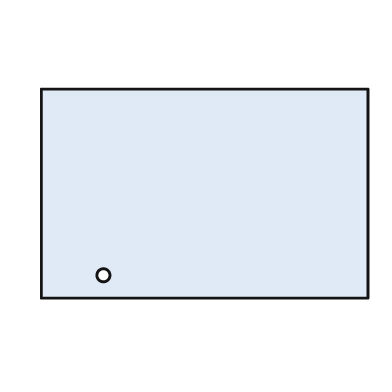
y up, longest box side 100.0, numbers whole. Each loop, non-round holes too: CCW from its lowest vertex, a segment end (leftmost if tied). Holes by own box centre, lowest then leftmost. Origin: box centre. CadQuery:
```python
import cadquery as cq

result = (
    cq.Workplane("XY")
    .moveTo(-50.0, -32.0)
    .lineTo(50.0, -32.0)
    .lineTo(50.0, 32.0)
    .lineTo(-50.0, 32.0)
    .close()
    .moveTo(-31.0, -25.0)
    .circle(2.0)
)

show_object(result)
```